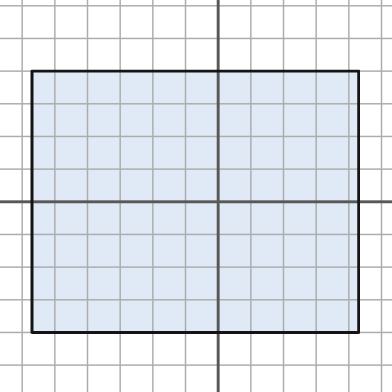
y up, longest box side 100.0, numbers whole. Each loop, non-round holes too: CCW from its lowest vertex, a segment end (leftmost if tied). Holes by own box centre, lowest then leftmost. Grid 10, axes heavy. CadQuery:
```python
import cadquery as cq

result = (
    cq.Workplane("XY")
    .moveTo(-57.0, -40.0)
    .lineTo(43.0, -40.0)
    .lineTo(43.0, 40.0)
    .lineTo(-57.0, 40.0)
    .close()
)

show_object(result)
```